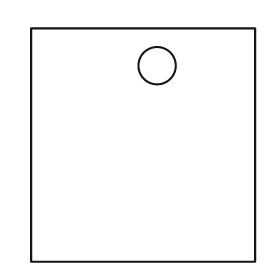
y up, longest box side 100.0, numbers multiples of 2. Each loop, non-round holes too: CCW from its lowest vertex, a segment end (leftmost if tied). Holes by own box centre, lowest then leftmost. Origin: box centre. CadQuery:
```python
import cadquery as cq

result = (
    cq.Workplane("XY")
    .moveTo(-48.0, -50.0)
    .lineTo(48.0, -50.0)
    .lineTo(48.0, 50.0)
    .lineTo(-48.0, 50.0)
    .close()
    .moveTo(6.0, 34.0)
    .circle(8.0)
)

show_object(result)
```